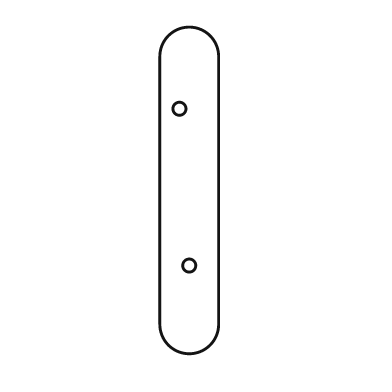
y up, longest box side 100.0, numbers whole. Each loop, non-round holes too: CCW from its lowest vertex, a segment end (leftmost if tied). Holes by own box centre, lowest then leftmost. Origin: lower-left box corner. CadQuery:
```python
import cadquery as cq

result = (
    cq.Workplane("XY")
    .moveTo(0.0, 9.0)
    .threePointArc((9.0, 0.0), (18.0, 9.0))
    .lineTo(18.0, 91.0)
    .threePointArc((9.0, 100.0), (0.0, 91.0))
    .close()
    .moveTo(9.0, 27.0)
    .circle(2.0)
    .moveTo(6.0, 75.0)
    .circle(2.0)
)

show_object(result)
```